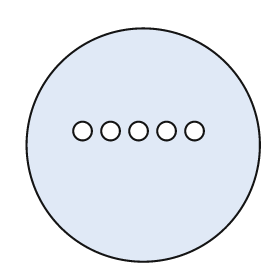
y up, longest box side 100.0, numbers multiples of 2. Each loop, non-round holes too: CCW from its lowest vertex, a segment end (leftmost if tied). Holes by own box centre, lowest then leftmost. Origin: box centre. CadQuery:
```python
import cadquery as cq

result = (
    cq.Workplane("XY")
    .moveTo(0.0, 0.0)
    .circle(50.0)
    .moveTo(-26.0, 6.0)
    .circle(4.0)
    .moveTo(-14.0, 6.0)
    .circle(4.0)
    .moveTo(-2.0, 6.0)
    .circle(4.0)
    .moveTo(10.0, 6.0)
    .circle(4.0)
    .moveTo(22.0, 6.0)
    .circle(4.0)
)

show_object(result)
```